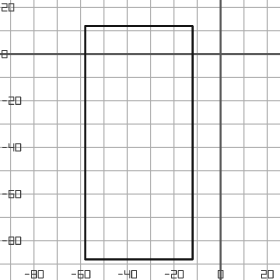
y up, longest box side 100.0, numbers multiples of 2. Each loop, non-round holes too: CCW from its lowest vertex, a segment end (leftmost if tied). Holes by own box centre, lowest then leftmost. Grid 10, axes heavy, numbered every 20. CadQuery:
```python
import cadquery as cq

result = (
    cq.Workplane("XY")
    .moveTo(-58.0, -88.0)
    .lineTo(-12.0, -88.0)
    .lineTo(-12.0, 12.0)
    .lineTo(-58.0, 12.0)
    .close()
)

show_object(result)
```